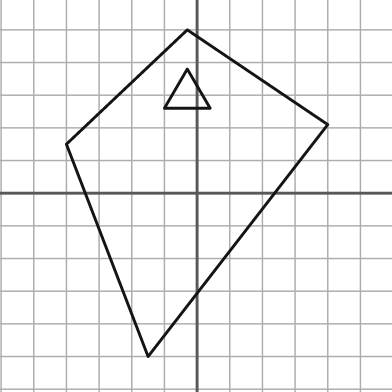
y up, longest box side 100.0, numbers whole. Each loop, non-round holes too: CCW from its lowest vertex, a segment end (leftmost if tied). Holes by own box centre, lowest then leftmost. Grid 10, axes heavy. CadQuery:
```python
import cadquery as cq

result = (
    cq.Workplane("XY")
    .moveTo(-15.0, -50.0)
    .lineTo(40.0, 21.0)
    .lineTo(-3.0, 50.0)
    .lineTo(-40.0, 15.0)
    .close()
    .moveTo(-10.0, 26.0)
    .lineTo(4.0, 26.0)
    .lineTo(-3.0, 38.0)
    .close()
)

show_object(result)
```